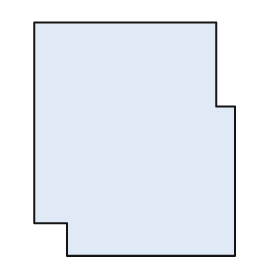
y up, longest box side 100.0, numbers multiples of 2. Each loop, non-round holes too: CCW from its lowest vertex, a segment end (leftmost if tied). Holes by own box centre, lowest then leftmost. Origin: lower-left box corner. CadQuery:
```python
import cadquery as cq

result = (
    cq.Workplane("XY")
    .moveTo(14.0, 0.0)
    .lineTo(86.0, 0.0)
    .lineTo(86.0, 64.0)
    .lineTo(78.0, 64.0)
    .lineTo(78.0, 100.0)
    .lineTo(0.0, 100.0)
    .lineTo(0.0, 14.0)
    .lineTo(14.0, 14.0)
    .close()
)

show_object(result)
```